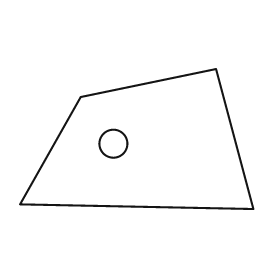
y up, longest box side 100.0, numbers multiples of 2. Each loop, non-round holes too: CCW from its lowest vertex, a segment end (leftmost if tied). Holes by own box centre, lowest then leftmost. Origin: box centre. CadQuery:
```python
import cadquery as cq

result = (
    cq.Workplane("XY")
    .moveTo(50.0, -30.0)
    .lineTo(34.0, 30.0)
    .lineTo(-24.0, 18.0)
    .lineTo(-50.0, -28.0)
    .close()
    .moveTo(-10.0, -2.0)
    .circle(6.0)
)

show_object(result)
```